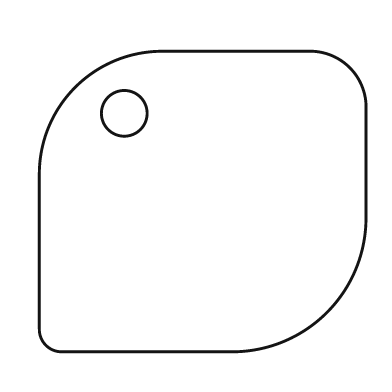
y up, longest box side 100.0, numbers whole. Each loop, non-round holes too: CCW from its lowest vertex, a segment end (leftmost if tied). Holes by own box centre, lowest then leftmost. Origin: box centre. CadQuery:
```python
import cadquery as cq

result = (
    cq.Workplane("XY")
    .moveTo(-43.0, -46.0)
    .lineTo(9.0, -46.0)
    .threePointArc((38.0, -34.0), (50.0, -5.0))
    .lineTo(50.0, 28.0)
    .threePointArc((45.0, 41.0), (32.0, 46.0))
    .lineTo(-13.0, 46.0)
    .threePointArc((-39.0, 35.0), (-50.0, 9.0))
    .lineTo(-50.0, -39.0)
    .threePointArc((-48.0, -44.0), (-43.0, -46.0))
    .close()
    .moveTo(-24.0, 27.0)
    .circle(7.0)
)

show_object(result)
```